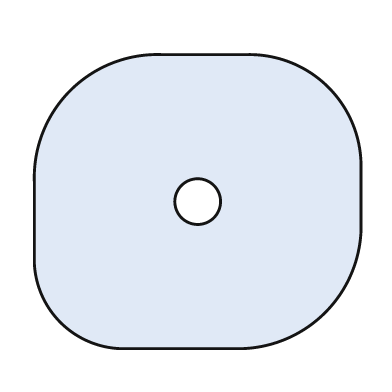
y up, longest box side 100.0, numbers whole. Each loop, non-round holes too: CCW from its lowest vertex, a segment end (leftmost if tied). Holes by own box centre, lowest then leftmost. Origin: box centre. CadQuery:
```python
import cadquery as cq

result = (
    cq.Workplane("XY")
    .moveTo(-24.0, -45.0)
    .lineTo(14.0, -45.0)
    .threePointArc((39.0, -34.0), (50.0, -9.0))
    .lineTo(50.0, 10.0)
    .threePointArc((40.0, 35.0), (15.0, 45.0))
    .lineTo(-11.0, 45.0)
    .threePointArc((-39.0, 34.0), (-50.0, 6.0))
    .lineTo(-50.0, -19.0)
    .threePointArc((-42.0, -37.0), (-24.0, -45.0))
    .close()
    .moveTo(0.0, 0.0)
    .circle(7.0)
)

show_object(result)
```